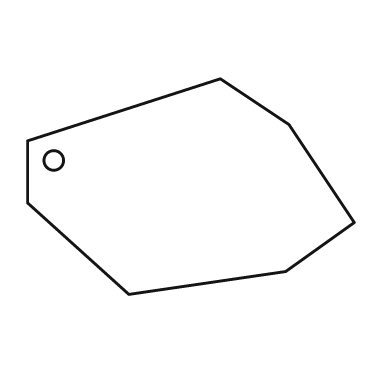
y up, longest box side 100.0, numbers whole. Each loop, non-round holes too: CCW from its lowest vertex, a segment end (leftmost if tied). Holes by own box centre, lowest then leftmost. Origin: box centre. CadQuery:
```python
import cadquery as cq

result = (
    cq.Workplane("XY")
    .moveTo(-19.0, -33.0)
    .lineTo(29.0, -26.0)
    .lineTo(50.0, -11.0)
    .lineTo(30.0, 19.0)
    .lineTo(9.0, 33.0)
    .lineTo(-50.0, 14.0)
    .lineTo(-50.0, -5.0)
    .close()
    .moveTo(-42.0, 8.0)
    .circle(3.0)
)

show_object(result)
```